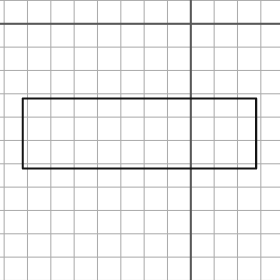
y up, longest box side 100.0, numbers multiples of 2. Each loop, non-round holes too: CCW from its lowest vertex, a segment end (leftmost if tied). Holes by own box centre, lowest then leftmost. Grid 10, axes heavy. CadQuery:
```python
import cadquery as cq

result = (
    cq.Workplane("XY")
    .moveTo(-72.0, -62.0)
    .lineTo(28.0, -62.0)
    .lineTo(28.0, -32.0)
    .lineTo(-72.0, -32.0)
    .close()
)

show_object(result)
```